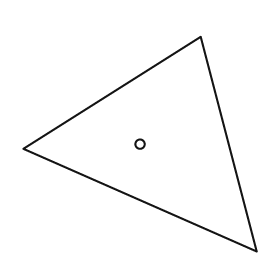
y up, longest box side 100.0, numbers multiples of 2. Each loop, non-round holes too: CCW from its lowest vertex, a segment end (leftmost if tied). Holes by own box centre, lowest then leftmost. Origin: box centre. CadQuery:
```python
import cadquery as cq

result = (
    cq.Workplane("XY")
    .moveTo(50.0, -46.0)
    .lineTo(26.0, 46.0)
    .lineTo(-50.0, -2.0)
    .close()
    .moveTo(0.0, 0.0)
    .circle(2.0)
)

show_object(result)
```